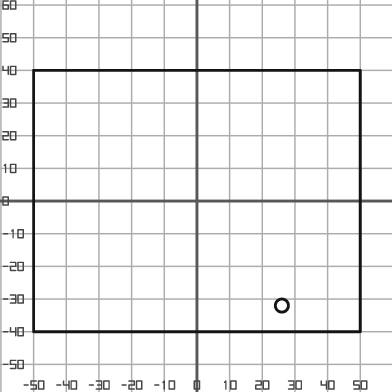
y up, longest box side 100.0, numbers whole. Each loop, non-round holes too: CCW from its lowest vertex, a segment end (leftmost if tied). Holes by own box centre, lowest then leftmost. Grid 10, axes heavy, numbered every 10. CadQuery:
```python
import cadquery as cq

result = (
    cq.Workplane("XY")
    .moveTo(-50.0, -40.0)
    .lineTo(50.0, -40.0)
    .lineTo(50.0, 40.0)
    .lineTo(-50.0, 40.0)
    .close()
    .moveTo(26.0, -32.0)
    .circle(2.0)
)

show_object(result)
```